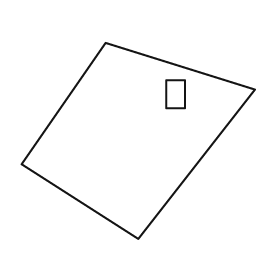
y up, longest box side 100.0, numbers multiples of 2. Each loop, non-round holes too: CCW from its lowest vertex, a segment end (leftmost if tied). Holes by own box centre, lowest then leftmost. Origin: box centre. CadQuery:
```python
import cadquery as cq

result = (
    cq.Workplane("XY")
    .moveTo(0.0, -42.0)
    .lineTo(50.0, 22.0)
    .lineTo(-14.0, 42.0)
    .lineTo(-50.0, -10.0)
    .close()
    .moveTo(12.0, 14.0)
    .lineTo(20.0, 14.0)
    .lineTo(20.0, 26.0)
    .lineTo(12.0, 26.0)
    .close()
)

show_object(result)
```